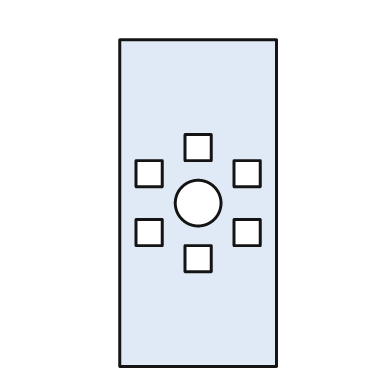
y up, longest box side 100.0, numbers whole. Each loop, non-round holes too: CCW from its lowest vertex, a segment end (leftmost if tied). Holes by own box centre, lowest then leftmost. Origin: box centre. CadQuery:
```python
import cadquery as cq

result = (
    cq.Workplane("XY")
    .moveTo(-24.0, -50.0)
    .lineTo(24.0, -50.0)
    .lineTo(24.0, 50.0)
    .lineTo(-24.0, 50.0)
    .close()
    .moveTo(-4.0, -21.0)
    .lineTo(4.0, -21.0)
    .lineTo(4.0, -13.0)
    .lineTo(-4.0, -13.0)
    .close()
    .moveTo(-19.0, -13.0)
    .lineTo(-11.0, -13.0)
    .lineTo(-11.0, -5.0)
    .lineTo(-19.0, -5.0)
    .close()
    .moveTo(11.0, -13.0)
    .lineTo(19.0, -13.0)
    .lineTo(19.0, -5.0)
    .lineTo(11.0, -5.0)
    .close()
    .moveTo(0.0, 0.0)
    .circle(7.0)
    .moveTo(-19.0, 5.0)
    .lineTo(-11.0, 5.0)
    .lineTo(-11.0, 13.0)
    .lineTo(-19.0, 13.0)
    .close()
    .moveTo(11.0, 5.0)
    .lineTo(19.0, 5.0)
    .lineTo(19.0, 13.0)
    .lineTo(11.0, 13.0)
    .close()
    .moveTo(-4.0, 13.0)
    .lineTo(4.0, 13.0)
    .lineTo(4.0, 21.0)
    .lineTo(-4.0, 21.0)
    .close()
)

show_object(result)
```